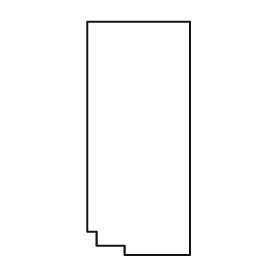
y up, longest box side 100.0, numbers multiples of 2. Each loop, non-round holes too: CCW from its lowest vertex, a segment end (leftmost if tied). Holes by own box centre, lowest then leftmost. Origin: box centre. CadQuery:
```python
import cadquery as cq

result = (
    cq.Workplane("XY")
    .moveTo(-6.0, -50.0)
    .lineTo(22.0, -50.0)
    .lineTo(22.0, 50.0)
    .lineTo(-22.0, 50.0)
    .lineTo(-22.0, -40.0)
    .lineTo(-18.0, -40.0)
    .lineTo(-18.0, -46.0)
    .lineTo(-6.0, -46.0)
    .close()
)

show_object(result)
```